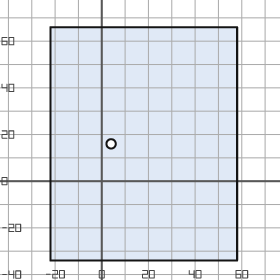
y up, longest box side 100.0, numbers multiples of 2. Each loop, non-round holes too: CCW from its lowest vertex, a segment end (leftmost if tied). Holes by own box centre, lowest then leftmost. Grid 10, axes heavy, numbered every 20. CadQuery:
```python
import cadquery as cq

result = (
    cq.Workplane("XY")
    .moveTo(-22.0, -34.0)
    .lineTo(58.0, -34.0)
    .lineTo(58.0, 66.0)
    .lineTo(-22.0, 66.0)
    .close()
    .moveTo(4.0, 16.0)
    .circle(2.0)
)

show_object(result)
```